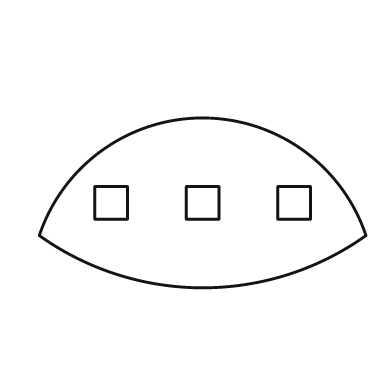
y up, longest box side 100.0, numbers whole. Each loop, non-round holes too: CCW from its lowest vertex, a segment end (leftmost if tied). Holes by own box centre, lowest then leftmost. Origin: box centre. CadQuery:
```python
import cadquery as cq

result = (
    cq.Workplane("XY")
    .moveTo(-50.0, -10.0)
    .threePointArc((0.0, -26.0), (50.0, -10.0))
    .threePointArc((0.0, 26.0), (-50.0, -10.0))
    .close()
    .moveTo(-33.0, -5.0)
    .lineTo(-23.0, -5.0)
    .lineTo(-23.0, 5.0)
    .lineTo(-33.0, 5.0)
    .close()
    .moveTo(-5.0, -5.0)
    .lineTo(5.0, -5.0)
    .lineTo(5.0, 5.0)
    .lineTo(-5.0, 5.0)
    .close()
    .moveTo(23.0, -5.0)
    .lineTo(33.0, -5.0)
    .lineTo(33.0, 5.0)
    .lineTo(23.0, 5.0)
    .close()
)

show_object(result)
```